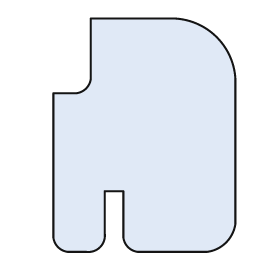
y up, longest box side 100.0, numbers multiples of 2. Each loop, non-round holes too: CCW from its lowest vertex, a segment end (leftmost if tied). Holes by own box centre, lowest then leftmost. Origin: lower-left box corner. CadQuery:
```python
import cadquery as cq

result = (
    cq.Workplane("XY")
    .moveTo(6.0, 0.0)
    .lineTo(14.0, 0.0)
    .threePointArc((20.0, 2.0), (22.0, 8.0))
    .lineTo(22.0, 26.0)
    .lineTo(30.0, 26.0)
    .lineTo(30.0, 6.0)
    .threePointArc((32.0, 2.0), (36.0, 0.0))
    .lineTo(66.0, 0.0)
    .threePointArc((74.0, 4.0), (78.0, 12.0))
    .lineTo(78.0, 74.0)
    .threePointArc((70.0, 92.0), (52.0, 100.0))
    .lineTo(16.0, 100.0)
    .lineTo(16.0, 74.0)
    .threePointArc((14.0, 70.0), (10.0, 68.0))
    .lineTo(0.0, 68.0)
    .lineTo(0.0, 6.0)
    .threePointArc((2.0, 2.0), (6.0, 0.0))
    .close()
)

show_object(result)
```